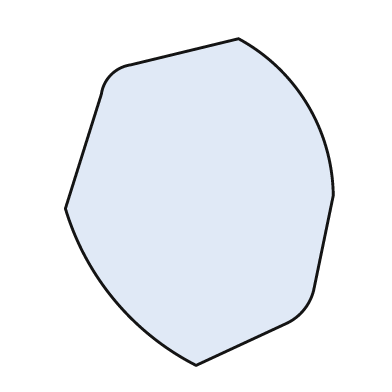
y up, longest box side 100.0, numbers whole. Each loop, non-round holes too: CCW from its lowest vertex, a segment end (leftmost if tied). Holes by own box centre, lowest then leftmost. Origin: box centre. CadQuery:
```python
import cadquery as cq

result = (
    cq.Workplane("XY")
    .moveTo(-1.0, -50.0)
    .lineTo(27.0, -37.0)
    .threePointArc((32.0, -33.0), (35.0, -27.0))
    .lineTo(41.0, 2.0)
    .threePointArc((33.0, 30.0), (12.0, 50.0))
    .lineTo(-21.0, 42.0)
    .threePointArc((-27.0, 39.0), (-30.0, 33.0))
    .lineTo(-41.0, -2.0)
    .threePointArc((-26.0, -30.0), (-1.0, -50.0))
    .close()
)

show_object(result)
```